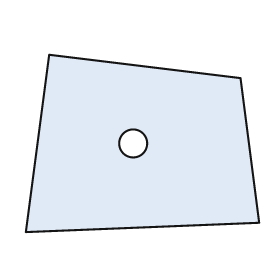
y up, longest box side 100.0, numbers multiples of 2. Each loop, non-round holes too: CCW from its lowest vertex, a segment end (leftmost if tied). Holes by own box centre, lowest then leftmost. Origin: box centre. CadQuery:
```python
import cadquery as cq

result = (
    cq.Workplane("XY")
    .moveTo(-50.0, -38.0)
    .lineTo(50.0, -34.0)
    .lineTo(42.0, 28.0)
    .lineTo(-40.0, 38.0)
    .close()
    .moveTo(-4.0, 0.0)
    .circle(6.0)
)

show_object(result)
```